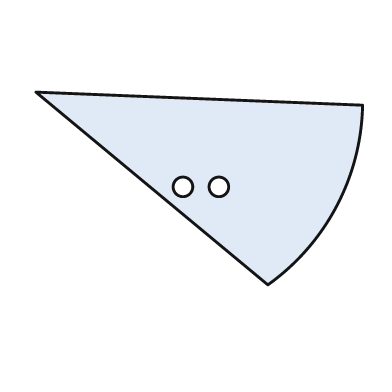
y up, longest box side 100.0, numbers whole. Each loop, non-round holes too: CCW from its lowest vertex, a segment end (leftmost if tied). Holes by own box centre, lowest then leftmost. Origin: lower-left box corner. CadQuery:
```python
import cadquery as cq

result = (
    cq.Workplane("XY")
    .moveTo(71.0, 0.0)
    .threePointArc((92.0, 24.0), (100.0, 55.0))
    .lineTo(0.0, 59.0)
    .close()
    .moveTo(45.0, 30.0)
    .circle(3.0)
    .moveTo(56.0, 30.0)
    .circle(3.0)
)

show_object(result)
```